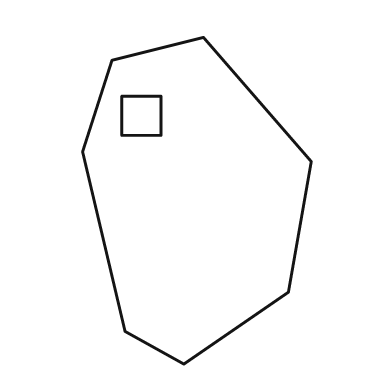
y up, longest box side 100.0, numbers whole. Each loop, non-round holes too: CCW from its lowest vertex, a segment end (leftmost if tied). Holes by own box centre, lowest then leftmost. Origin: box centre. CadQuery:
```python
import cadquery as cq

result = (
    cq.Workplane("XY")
    .moveTo(-4.0, -50.0)
    .lineTo(28.0, -28.0)
    .lineTo(35.0, 12.0)
    .lineTo(2.0, 50.0)
    .lineTo(-26.0, 43.0)
    .lineTo(-35.0, 15.0)
    .lineTo(-22.0, -40.0)
    .close()
    .moveTo(-23.0, 20.0)
    .lineTo(-11.0, 20.0)
    .lineTo(-11.0, 32.0)
    .lineTo(-23.0, 32.0)
    .close()
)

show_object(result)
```